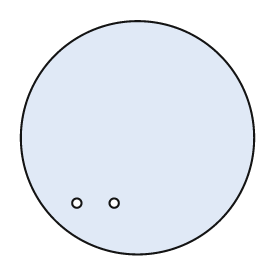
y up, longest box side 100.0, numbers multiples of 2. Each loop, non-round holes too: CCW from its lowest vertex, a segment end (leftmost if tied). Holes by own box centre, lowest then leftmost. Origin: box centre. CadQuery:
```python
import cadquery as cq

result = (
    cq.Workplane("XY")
    .moveTo(0.0, 0.0)
    .circle(50.0)
    .moveTo(-26.0, -28.0)
    .circle(2.0)
    .moveTo(-10.0, -28.0)
    .circle(2.0)
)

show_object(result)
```